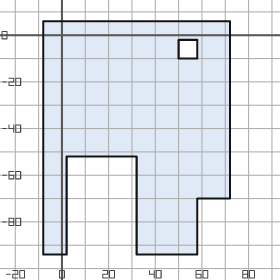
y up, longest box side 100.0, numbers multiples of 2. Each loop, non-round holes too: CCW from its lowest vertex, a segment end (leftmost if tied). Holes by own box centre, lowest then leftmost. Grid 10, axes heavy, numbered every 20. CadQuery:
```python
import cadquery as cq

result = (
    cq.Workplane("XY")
    .moveTo(-8.0, -94.0)
    .lineTo(2.0, -94.0)
    .lineTo(2.0, -52.0)
    .lineTo(32.0, -52.0)
    .lineTo(32.0, -94.0)
    .lineTo(58.0, -94.0)
    .lineTo(58.0, -70.0)
    .lineTo(72.0, -70.0)
    .lineTo(72.0, 6.0)
    .lineTo(-8.0, 6.0)
    .close()
    .moveTo(50.0, -10.0)
    .lineTo(58.0, -10.0)
    .lineTo(58.0, -2.0)
    .lineTo(50.0, -2.0)
    .close()
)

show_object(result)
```